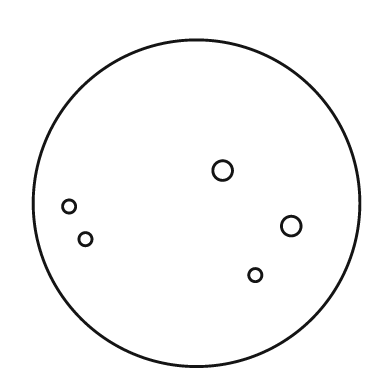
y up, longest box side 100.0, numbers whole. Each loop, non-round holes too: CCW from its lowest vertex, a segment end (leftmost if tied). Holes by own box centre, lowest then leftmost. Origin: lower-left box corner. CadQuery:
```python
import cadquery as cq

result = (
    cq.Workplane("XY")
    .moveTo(50.0, 50.0)
    .circle(50.0)
    .moveTo(68.0, 28.0)
    .circle(2.0)
    .moveTo(16.0, 39.0)
    .circle(2.0)
    .moveTo(79.0, 43.0)
    .circle(3.0)
    .moveTo(11.0, 49.0)
    .circle(2.0)
    .moveTo(58.0, 60.0)
    .circle(3.0)
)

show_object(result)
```